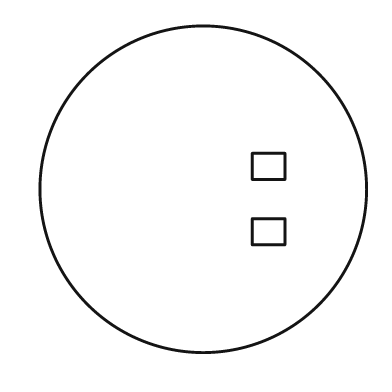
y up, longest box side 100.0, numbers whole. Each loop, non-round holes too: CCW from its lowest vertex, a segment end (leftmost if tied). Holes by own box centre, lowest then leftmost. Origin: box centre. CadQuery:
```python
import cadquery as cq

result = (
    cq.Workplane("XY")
    .moveTo(0.0, 0.0)
    .circle(50.0)
    .moveTo(15.0, -17.0)
    .lineTo(25.0, -17.0)
    .lineTo(25.0, -9.0)
    .lineTo(15.0, -9.0)
    .close()
    .moveTo(15.0, 3.0)
    .lineTo(25.0, 3.0)
    .lineTo(25.0, 11.0)
    .lineTo(15.0, 11.0)
    .close()
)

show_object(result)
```